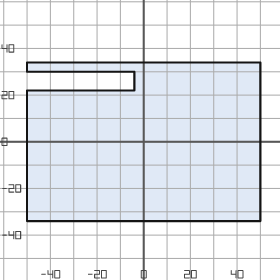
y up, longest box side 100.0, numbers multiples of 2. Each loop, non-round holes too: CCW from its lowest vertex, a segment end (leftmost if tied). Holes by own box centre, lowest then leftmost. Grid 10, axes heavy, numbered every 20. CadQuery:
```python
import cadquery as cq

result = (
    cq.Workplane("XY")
    .moveTo(-50.0, -34.0)
    .lineTo(50.0, -34.0)
    .lineTo(50.0, 34.0)
    .lineTo(-50.0, 34.0)
    .lineTo(-50.0, 30.0)
    .lineTo(-4.0, 30.0)
    .lineTo(-4.0, 22.0)
    .lineTo(-50.0, 22.0)
    .close()
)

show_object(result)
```